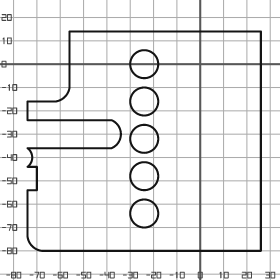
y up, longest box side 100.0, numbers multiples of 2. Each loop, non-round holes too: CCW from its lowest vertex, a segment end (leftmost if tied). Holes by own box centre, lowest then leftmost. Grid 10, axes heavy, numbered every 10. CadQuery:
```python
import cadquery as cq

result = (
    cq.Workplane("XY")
    .moveTo(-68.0, -80.0)
    .lineTo(26.0, -80.0)
    .lineTo(26.0, 14.0)
    .lineTo(-56.0, 14.0)
    .lineTo(-56.0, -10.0)
    .threePointArc((-58.0, -14.0), (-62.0, -16.0))
    .lineTo(-74.0, -16.0)
    .lineTo(-74.0, -24.0)
    .lineTo(-38.0, -24.0)
    .threePointArc((-34.0, -30.0), (-38.0, -36.0))
    .lineTo(-74.0, -36.0)
    .threePointArc((-72.0, -40.0), (-74.0, -44.0))
    .lineTo(-70.0, -44.0)
    .lineTo(-70.0, -54.0)
    .lineTo(-74.0, -54.0)
    .lineTo(-74.0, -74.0)
    .threePointArc((-72.0, -78.0), (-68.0, -80.0))
    .close()
    .moveTo(-24.0, -64.0)
    .circle(6.0)
    .moveTo(-24.0, -48.0)
    .circle(6.0)
    .moveTo(-24.0, -32.0)
    .circle(6.0)
    .moveTo(-24.0, -16.0)
    .circle(6.0)
    .moveTo(-24.0, 0.0)
    .circle(6.0)
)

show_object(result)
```